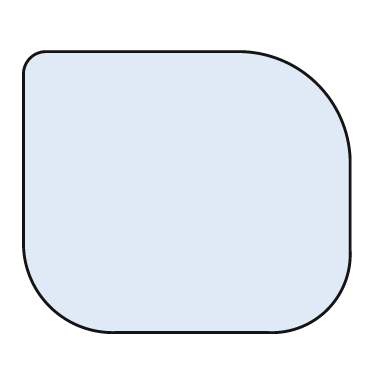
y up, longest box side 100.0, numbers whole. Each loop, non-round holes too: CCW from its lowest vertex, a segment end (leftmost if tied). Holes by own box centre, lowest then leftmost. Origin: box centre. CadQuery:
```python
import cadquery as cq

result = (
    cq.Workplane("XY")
    .moveTo(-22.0, -43.0)
    .lineTo(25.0, -43.0)
    .threePointArc((43.0, -36.0), (50.0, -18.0))
    .lineTo(50.0, 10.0)
    .threePointArc((40.0, 33.0), (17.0, 43.0))
    .lineTo(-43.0, 43.0)
    .threePointArc((-48.0, 41.0), (-50.0, 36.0))
    .lineTo(-50.0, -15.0)
    .threePointArc((-42.0, -35.0), (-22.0, -43.0))
    .close()
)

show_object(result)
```